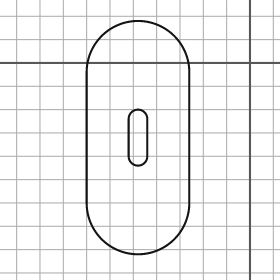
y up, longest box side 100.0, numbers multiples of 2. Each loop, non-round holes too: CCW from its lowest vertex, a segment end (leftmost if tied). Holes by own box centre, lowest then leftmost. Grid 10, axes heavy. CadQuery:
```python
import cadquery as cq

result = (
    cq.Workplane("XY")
    .moveTo(-70.0, -60.0)
    .threePointArc((-48.0, -82.0), (-26.0, -60.0))
    .lineTo(-26.0, -4.0)
    .threePointArc((-48.0, 18.0), (-70.0, -4.0))
    .close()
    .moveTo(-52.0, -40.0)
    .threePointArc((-48.0, -44.0), (-44.0, -40.0))
    .lineTo(-44.0, -24.0)
    .threePointArc((-48.0, -20.0), (-52.0, -24.0))
    .close()
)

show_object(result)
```